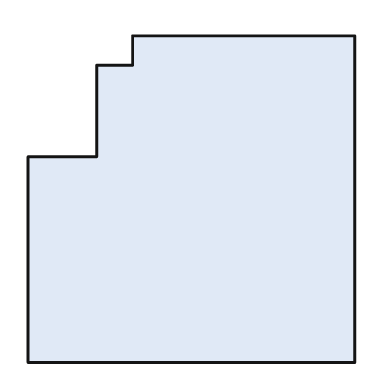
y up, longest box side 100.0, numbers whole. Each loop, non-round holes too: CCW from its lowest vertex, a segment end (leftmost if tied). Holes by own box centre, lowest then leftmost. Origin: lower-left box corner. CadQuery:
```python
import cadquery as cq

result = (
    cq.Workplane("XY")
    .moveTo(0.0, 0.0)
    .lineTo(100.0, 0.0)
    .lineTo(100.0, 100.0)
    .lineTo(32.0, 100.0)
    .lineTo(32.0, 91.0)
    .lineTo(21.0, 91.0)
    .lineTo(21.0, 63.0)
    .lineTo(0.0, 63.0)
    .close()
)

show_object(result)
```